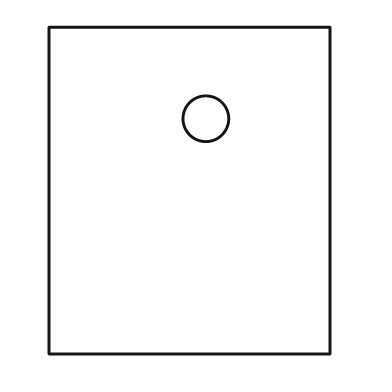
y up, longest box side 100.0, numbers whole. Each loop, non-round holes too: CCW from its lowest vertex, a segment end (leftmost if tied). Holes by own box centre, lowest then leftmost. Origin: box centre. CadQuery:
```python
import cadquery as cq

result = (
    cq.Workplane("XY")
    .moveTo(-43.0, -50.0)
    .lineTo(43.0, -50.0)
    .lineTo(43.0, 50.0)
    .lineTo(-43.0, 50.0)
    .close()
    .moveTo(5.0, 22.0)
    .circle(7.0)
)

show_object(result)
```